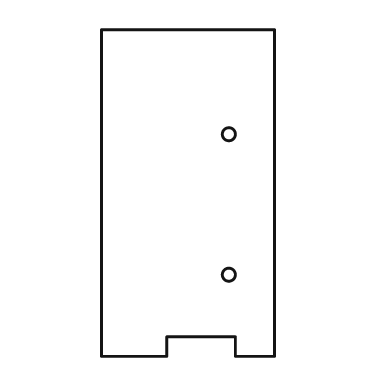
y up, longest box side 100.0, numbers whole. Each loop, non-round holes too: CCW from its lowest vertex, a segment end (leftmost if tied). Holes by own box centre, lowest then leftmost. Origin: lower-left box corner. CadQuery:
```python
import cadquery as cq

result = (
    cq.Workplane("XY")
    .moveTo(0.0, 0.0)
    .lineTo(20.0, 0.0)
    .lineTo(20.0, 6.0)
    .lineTo(41.0, 6.0)
    .lineTo(41.0, 0.0)
    .lineTo(53.0, 0.0)
    .lineTo(53.0, 100.0)
    .lineTo(0.0, 100.0)
    .close()
    .moveTo(39.0, 25.0)
    .circle(2.0)
    .moveTo(39.0, 68.0)
    .circle(2.0)
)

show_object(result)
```